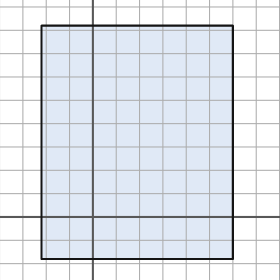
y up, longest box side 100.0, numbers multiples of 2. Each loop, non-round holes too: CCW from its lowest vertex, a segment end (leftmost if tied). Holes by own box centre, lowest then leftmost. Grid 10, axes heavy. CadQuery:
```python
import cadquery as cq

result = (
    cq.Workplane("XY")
    .moveTo(-22.0, -18.0)
    .lineTo(60.0, -18.0)
    .lineTo(60.0, 82.0)
    .lineTo(-22.0, 82.0)
    .close()
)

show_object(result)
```